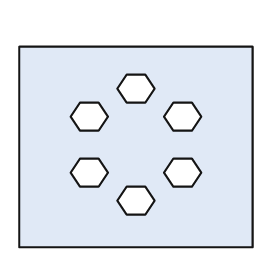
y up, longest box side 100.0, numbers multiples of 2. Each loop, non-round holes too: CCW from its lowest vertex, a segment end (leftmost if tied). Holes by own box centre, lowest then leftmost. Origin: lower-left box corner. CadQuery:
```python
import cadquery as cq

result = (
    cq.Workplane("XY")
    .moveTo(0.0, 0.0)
    .lineTo(100.0, 0.0)
    .lineTo(100.0, 86.0)
    .lineTo(0.0, 86.0)
    .close()
    .moveTo(46.0, 14.0)
    .lineTo(54.0, 14.0)
    .lineTo(58.0, 20.0)
    .lineTo(54.0, 26.0)
    .lineTo(46.0, 26.0)
    .lineTo(42.0, 20.0)
    .close()
    .moveTo(26.0, 26.0)
    .lineTo(34.0, 26.0)
    .lineTo(38.0, 32.0)
    .lineTo(34.0, 38.0)
    .lineTo(26.0, 38.0)
    .lineTo(22.0, 32.0)
    .close()
    .moveTo(66.0, 26.0)
    .lineTo(74.0, 26.0)
    .lineTo(78.0, 32.0)
    .lineTo(74.0, 38.0)
    .lineTo(66.0, 38.0)
    .lineTo(62.0, 32.0)
    .close()
    .moveTo(26.0, 50.0)
    .lineTo(34.0, 50.0)
    .lineTo(38.0, 56.0)
    .lineTo(34.0, 62.0)
    .lineTo(26.0, 62.0)
    .lineTo(22.0, 56.0)
    .close()
    .moveTo(66.0, 50.0)
    .lineTo(74.0, 50.0)
    .lineTo(78.0, 56.0)
    .lineTo(74.0, 62.0)
    .lineTo(66.0, 62.0)
    .lineTo(62.0, 56.0)
    .close()
    .moveTo(46.0, 62.0)
    .lineTo(54.0, 62.0)
    .lineTo(58.0, 68.0)
    .lineTo(54.0, 74.0)
    .lineTo(46.0, 74.0)
    .lineTo(42.0, 68.0)
    .close()
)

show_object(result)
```